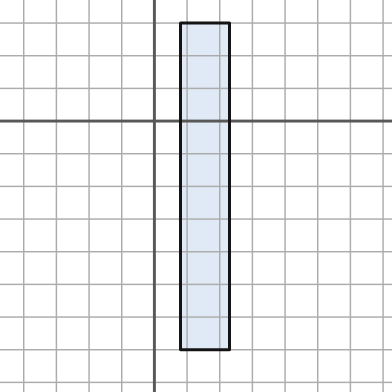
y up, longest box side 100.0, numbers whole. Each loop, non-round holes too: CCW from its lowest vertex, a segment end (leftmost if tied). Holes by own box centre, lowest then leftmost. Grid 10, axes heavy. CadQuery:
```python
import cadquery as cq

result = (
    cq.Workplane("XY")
    .moveTo(8.0, -70.0)
    .lineTo(23.0, -70.0)
    .lineTo(23.0, 30.0)
    .lineTo(8.0, 30.0)
    .close()
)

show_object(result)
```